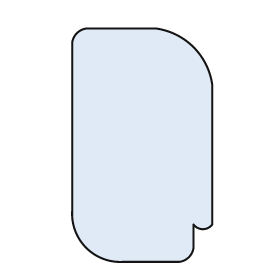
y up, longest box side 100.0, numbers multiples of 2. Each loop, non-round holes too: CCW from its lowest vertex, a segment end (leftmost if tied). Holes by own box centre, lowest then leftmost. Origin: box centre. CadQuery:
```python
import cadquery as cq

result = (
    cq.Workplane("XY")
    .moveTo(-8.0, -50.0)
    .lineTo(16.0, -50.0)
    .threePointArc((20.0, -48.0), (22.0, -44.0))
    .lineTo(22.0, -34.0)
    .threePointArc((26.0, -36.0), (30.0, -34.0))
    .lineTo(30.0, 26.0)
    .threePointArc((22.0, 42.0), (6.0, 50.0))
    .lineTo(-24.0, 50.0)
    .threePointArc((-28.0, 48.0), (-30.0, 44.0))
    .lineTo(-30.0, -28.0)
    .threePointArc((-24.0, -44.0), (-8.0, -50.0))
    .close()
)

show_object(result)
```